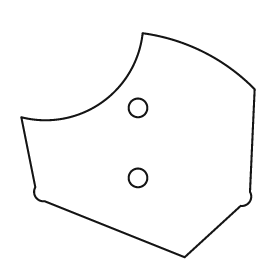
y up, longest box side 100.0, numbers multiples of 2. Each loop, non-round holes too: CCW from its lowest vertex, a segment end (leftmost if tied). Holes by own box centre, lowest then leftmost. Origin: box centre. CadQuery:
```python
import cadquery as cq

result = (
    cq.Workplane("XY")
    .moveTo(20.0, -48.0)
    .lineTo(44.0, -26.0)
    .threePointArc((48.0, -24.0), (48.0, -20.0))
    .lineTo(50.0, 24.0)
    .threePointArc((28.0, 40.0), (2.0, 48.0))
    .threePointArc((-16.0, 18.0), (-50.0, 12.0))
    .lineTo(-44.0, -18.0)
    .threePointArc((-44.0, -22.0), (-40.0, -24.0))
    .close()
    .moveTo(0.0, -14.0)
    .circle(4.0)
    .moveTo(0.0, 16.0)
    .circle(4.0)
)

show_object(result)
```